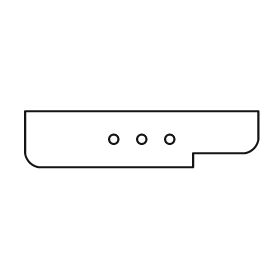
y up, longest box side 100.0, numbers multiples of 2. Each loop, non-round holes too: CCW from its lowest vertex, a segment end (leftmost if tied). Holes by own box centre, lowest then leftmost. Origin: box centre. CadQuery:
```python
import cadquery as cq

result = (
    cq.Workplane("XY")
    .moveTo(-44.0, -12.0)
    .lineTo(22.0, -12.0)
    .lineTo(22.0, -6.0)
    .lineTo(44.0, -6.0)
    .threePointArc((48.0, -4.0), (50.0, 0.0))
    .lineTo(50.0, 12.0)
    .lineTo(-50.0, 12.0)
    .lineTo(-50.0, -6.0)
    .threePointArc((-48.0, -10.0), (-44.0, -12.0))
    .close()
    .moveTo(-12.0, 0.0)
    .circle(2.0)
    .moveTo(0.0, 0.0)
    .circle(2.0)
    .moveTo(12.0, 0.0)
    .circle(2.0)
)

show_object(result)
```